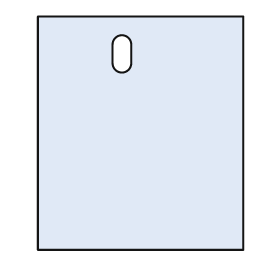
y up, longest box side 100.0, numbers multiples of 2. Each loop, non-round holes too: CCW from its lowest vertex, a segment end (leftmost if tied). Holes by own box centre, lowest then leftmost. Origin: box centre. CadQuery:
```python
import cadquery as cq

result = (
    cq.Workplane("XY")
    .moveTo(-44.0, -50.0)
    .lineTo(44.0, -50.0)
    .lineTo(44.0, 50.0)
    .lineTo(-44.0, 50.0)
    .close()
    .moveTo(-12.0, 30.0)
    .threePointArc((-8.0, 26.0), (-4.0, 30.0))
    .lineTo(-4.0, 38.0)
    .threePointArc((-8.0, 42.0), (-12.0, 38.0))
    .close()
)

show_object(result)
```